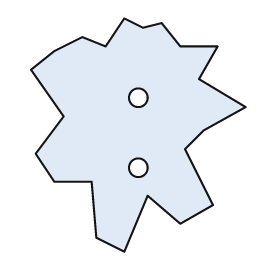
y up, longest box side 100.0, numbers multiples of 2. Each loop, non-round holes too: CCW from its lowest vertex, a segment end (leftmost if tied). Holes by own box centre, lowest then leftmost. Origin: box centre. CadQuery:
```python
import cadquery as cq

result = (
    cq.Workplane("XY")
    .moveTo(-6.0, -50.0)
    .lineTo(4.0, -26.0)
    .lineTo(18.0, -38.0)
    .lineTo(32.0, -30.0)
    .lineTo(20.0, -6.0)
    .lineTo(28.0, 2.0)
    .lineTo(46.0, 12.0)
    .lineTo(26.0, 24.0)
    .lineTo(34.0, 38.0)
    .lineTo(18.0, 38.0)
    .lineTo(10.0, 48.0)
    .lineTo(2.0, 46.0)
    .lineTo(-6.0, 50.0)
    .lineTo(-14.0, 38.0)
    .lineTo(-24.0, 42.0)
    .lineTo(-36.0, 36.0)
    .lineTo(-46.0, 28.0)
    .lineTo(-32.0, 8.0)
    .lineTo(-44.0, -8.0)
    .lineTo(-36.0, -20.0)
    .lineTo(-20.0, -20.0)
    .lineTo(-18.0, -44.0)
    .close()
    .moveTo(0.0, -14.0)
    .circle(4.0)
    .moveTo(0.0, 16.0)
    .circle(4.0)
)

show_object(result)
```